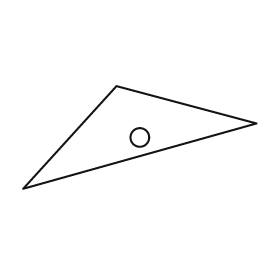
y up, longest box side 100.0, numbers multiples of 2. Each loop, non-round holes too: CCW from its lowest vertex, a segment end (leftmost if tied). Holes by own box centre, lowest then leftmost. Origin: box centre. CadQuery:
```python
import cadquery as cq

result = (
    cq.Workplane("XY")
    .moveTo(-50.0, -22.0)
    .lineTo(50.0, 6.0)
    .lineTo(-10.0, 22.0)
    .close()
    .moveTo(0.0, 0.0)
    .circle(4.0)
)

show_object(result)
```